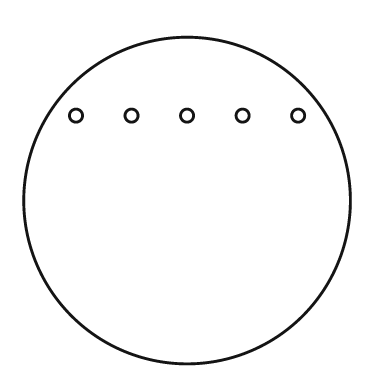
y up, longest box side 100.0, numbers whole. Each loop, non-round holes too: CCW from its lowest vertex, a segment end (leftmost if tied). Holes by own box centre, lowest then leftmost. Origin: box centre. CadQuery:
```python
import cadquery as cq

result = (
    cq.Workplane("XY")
    .moveTo(0.0, 0.0)
    .circle(50.0)
    .moveTo(-34.0, 26.0)
    .circle(2.0)
    .moveTo(-17.0, 26.0)
    .circle(2.0)
    .moveTo(0.0, 26.0)
    .circle(2.0)
    .moveTo(17.0, 26.0)
    .circle(2.0)
    .moveTo(34.0, 26.0)
    .circle(2.0)
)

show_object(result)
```